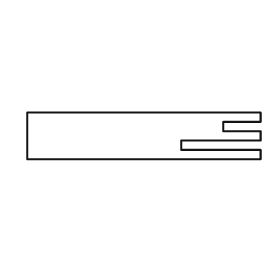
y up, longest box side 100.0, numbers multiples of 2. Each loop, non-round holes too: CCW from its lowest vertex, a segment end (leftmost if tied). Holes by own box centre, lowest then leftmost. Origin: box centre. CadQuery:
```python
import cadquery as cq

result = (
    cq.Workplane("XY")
    .moveTo(-50.0, -10.0)
    .lineTo(50.0, -10.0)
    .lineTo(50.0, -6.0)
    .lineTo(16.0, -6.0)
    .lineTo(16.0, -2.0)
    .lineTo(50.0, -2.0)
    .lineTo(50.0, 2.0)
    .lineTo(34.0, 2.0)
    .lineTo(34.0, 6.0)
    .lineTo(50.0, 6.0)
    .lineTo(50.0, 10.0)
    .lineTo(-50.0, 10.0)
    .close()
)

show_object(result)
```